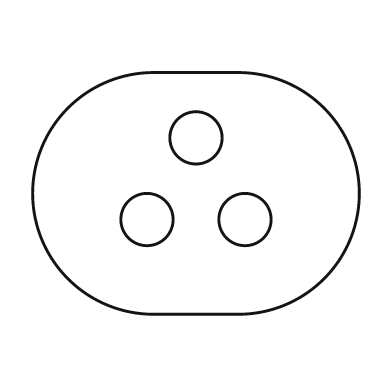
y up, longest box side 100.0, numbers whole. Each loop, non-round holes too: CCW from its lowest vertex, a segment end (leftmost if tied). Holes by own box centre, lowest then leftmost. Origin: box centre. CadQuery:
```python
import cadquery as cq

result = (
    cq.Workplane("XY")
    .moveTo(-13.0, -37.0)
    .lineTo(13.0, -37.0)
    .threePointArc((50.0, 0.0), (13.0, 37.0))
    .lineTo(-13.0, 37.0)
    .threePointArc((-50.0, 0.0), (-13.0, -37.0))
    .close()
    .moveTo(-15.0, -8.0)
    .circle(8.0)
    .moveTo(15.0, -8.0)
    .circle(8.0)
    .moveTo(0.0, 17.0)
    .circle(8.0)
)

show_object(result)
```